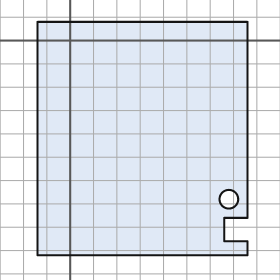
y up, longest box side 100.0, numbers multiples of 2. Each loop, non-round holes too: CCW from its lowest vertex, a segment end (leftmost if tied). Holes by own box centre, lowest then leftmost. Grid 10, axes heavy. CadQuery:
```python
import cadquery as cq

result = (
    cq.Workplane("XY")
    .moveTo(-14.0, -92.0)
    .lineTo(76.0, -92.0)
    .lineTo(76.0, -86.0)
    .lineTo(66.0, -86.0)
    .lineTo(66.0, -76.0)
    .lineTo(76.0, -76.0)
    .lineTo(76.0, 8.0)
    .lineTo(-14.0, 8.0)
    .close()
    .moveTo(68.0, -68.0)
    .circle(4.0)
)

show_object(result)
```